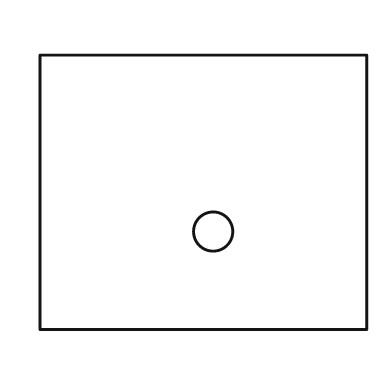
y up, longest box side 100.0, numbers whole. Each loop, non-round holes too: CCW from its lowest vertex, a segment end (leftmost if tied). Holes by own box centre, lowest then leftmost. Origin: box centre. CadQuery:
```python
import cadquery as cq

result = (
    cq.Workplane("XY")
    .moveTo(-50.0, -42.0)
    .lineTo(50.0, -42.0)
    .lineTo(50.0, 42.0)
    .lineTo(-50.0, 42.0)
    .close()
    .moveTo(3.0, -12.0)
    .circle(6.0)
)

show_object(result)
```